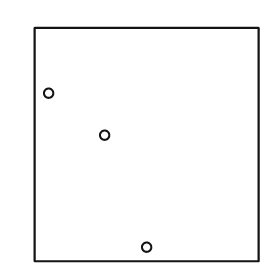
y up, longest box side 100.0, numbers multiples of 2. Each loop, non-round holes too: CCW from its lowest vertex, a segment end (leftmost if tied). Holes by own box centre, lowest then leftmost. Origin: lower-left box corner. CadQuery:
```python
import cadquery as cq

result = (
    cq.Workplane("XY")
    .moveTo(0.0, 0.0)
    .lineTo(96.0, 0.0)
    .lineTo(96.0, 100.0)
    .lineTo(0.0, 100.0)
    .close()
    .moveTo(48.0, 6.0)
    .circle(2.0)
    .moveTo(30.0, 54.0)
    .circle(2.0)
    .moveTo(6.0, 72.0)
    .circle(2.0)
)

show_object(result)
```